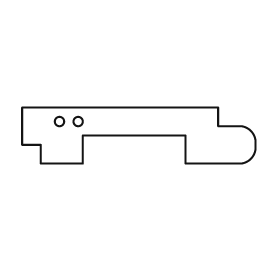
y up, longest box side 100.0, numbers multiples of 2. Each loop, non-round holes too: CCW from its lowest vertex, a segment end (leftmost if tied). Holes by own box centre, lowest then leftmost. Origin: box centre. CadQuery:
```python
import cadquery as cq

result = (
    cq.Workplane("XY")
    .moveTo(-42.0, -12.0)
    .lineTo(-24.0, -12.0)
    .lineTo(-24.0, 0.0)
    .lineTo(20.0, 0.0)
    .lineTo(20.0, -12.0)
    .lineTo(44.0, -12.0)
    .threePointArc((48.0, -10.0), (50.0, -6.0))
    .lineTo(50.0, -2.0)
    .threePointArc((48.0, 2.0), (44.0, 4.0))
    .lineTo(34.0, 4.0)
    .lineTo(34.0, 12.0)
    .lineTo(-50.0, 12.0)
    .lineTo(-50.0, -4.0)
    .lineTo(-42.0, -4.0)
    .close()
    .moveTo(-34.0, 6.0)
    .circle(2.0)
    .moveTo(-26.0, 6.0)
    .circle(2.0)
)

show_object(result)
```